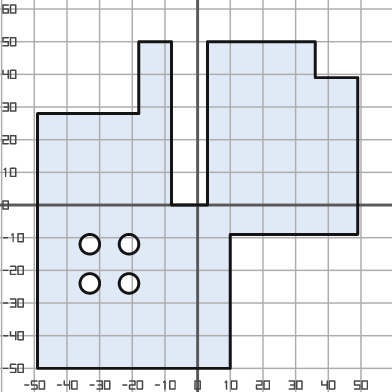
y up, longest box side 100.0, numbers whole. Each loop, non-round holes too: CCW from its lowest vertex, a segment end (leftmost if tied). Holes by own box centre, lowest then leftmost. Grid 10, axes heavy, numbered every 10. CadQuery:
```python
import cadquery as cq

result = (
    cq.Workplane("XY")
    .moveTo(-49.0, -50.0)
    .lineTo(10.0, -50.0)
    .lineTo(10.0, -9.0)
    .lineTo(49.0, -9.0)
    .lineTo(49.0, 39.0)
    .lineTo(36.0, 39.0)
    .lineTo(36.0, 50.0)
    .lineTo(3.0, 50.0)
    .lineTo(3.0, 0.0)
    .lineTo(-8.0, 0.0)
    .lineTo(-8.0, 50.0)
    .lineTo(-18.0, 50.0)
    .lineTo(-18.0, 28.0)
    .lineTo(-49.0, 28.0)
    .close()
    .moveTo(-33.0, -24.0)
    .circle(3.0)
    .moveTo(-21.0, -24.0)
    .circle(3.0)
    .moveTo(-33.0, -12.0)
    .circle(3.0)
    .moveTo(-21.0, -12.0)
    .circle(3.0)
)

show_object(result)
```